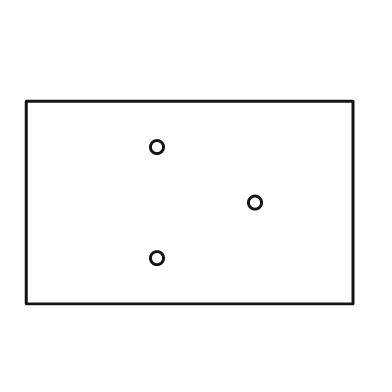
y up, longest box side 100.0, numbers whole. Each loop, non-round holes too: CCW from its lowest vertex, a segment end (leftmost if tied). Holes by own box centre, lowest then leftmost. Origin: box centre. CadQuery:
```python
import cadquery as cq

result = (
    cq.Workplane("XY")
    .moveTo(-50.0, -31.0)
    .lineTo(50.0, -31.0)
    .lineTo(50.0, 31.0)
    .lineTo(-50.0, 31.0)
    .close()
    .moveTo(-10.0, -17.0)
    .circle(2.0)
    .moveTo(20.0, 0.0)
    .circle(2.0)
    .moveTo(-10.0, 17.0)
    .circle(2.0)
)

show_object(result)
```